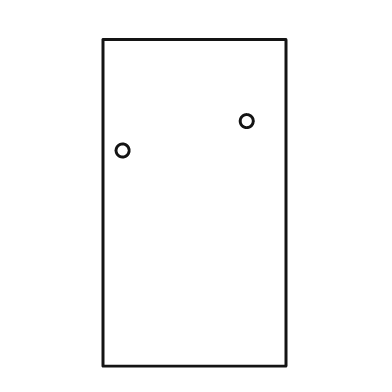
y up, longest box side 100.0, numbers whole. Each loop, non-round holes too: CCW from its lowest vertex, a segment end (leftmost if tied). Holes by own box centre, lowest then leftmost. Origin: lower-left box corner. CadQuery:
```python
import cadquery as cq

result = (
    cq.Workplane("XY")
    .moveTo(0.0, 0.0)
    .lineTo(56.0, 0.0)
    .lineTo(56.0, 100.0)
    .lineTo(0.0, 100.0)
    .close()
    .moveTo(6.0, 66.0)
    .circle(2.0)
    .moveTo(44.0, 75.0)
    .circle(2.0)
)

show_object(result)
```